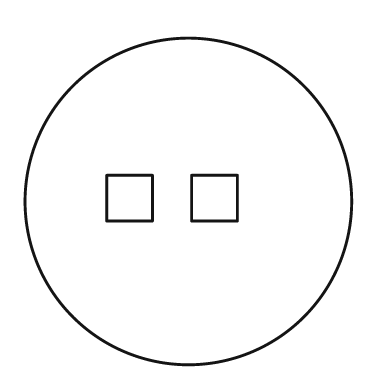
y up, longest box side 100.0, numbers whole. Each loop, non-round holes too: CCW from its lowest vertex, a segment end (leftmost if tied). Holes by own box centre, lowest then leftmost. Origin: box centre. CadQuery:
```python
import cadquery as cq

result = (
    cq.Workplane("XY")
    .moveTo(0.0, 0.0)
    .circle(50.0)
    .moveTo(-25.0, -6.0)
    .lineTo(-11.0, -6.0)
    .lineTo(-11.0, 8.0)
    .lineTo(-25.0, 8.0)
    .close()
    .moveTo(1.0, -6.0)
    .lineTo(15.0, -6.0)
    .lineTo(15.0, 8.0)
    .lineTo(1.0, 8.0)
    .close()
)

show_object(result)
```